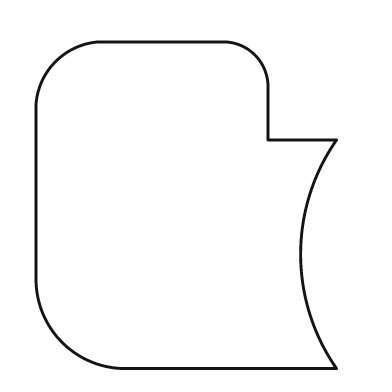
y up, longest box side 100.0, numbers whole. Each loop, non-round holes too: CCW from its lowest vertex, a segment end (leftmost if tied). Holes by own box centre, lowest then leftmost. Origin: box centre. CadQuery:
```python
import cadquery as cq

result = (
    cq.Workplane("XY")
    .moveTo(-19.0, -50.0)
    .lineTo(46.0, -50.0)
    .threePointArc((35.0, -15.0), (46.0, 20.0))
    .lineTo(25.0, 20.0)
    .lineTo(25.0, 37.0)
    .threePointArc((21.0, 46.0), (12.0, 50.0))
    .lineTo(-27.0, 50.0)
    .threePointArc((-40.0, 44.0), (-46.0, 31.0))
    .lineTo(-46.0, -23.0)
    .threePointArc((-38.0, -42.0), (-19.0, -50.0))
    .close()
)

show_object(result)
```